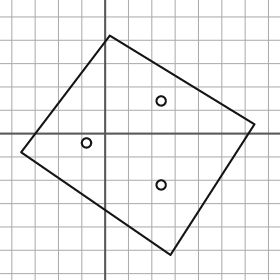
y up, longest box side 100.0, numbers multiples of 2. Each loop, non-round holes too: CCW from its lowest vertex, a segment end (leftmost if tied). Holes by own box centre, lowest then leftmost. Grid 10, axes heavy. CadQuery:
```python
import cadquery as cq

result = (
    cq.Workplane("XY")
    .moveTo(28.0, -52.0)
    .lineTo(64.0, 4.0)
    .lineTo(2.0, 42.0)
    .lineTo(-36.0, -8.0)
    .close()
    .moveTo(24.0, -22.0)
    .circle(2.0)
    .moveTo(-8.0, -4.0)
    .circle(2.0)
    .moveTo(24.0, 14.0)
    .circle(2.0)
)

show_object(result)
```